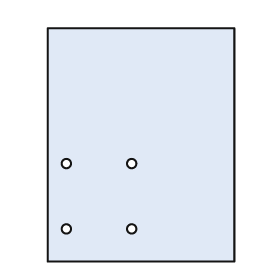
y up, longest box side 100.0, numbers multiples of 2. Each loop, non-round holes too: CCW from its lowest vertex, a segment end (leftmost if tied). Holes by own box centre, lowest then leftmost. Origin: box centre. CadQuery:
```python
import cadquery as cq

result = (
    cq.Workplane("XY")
    .moveTo(-40.0, -50.0)
    .lineTo(40.0, -50.0)
    .lineTo(40.0, 50.0)
    .lineTo(-40.0, 50.0)
    .close()
    .moveTo(-32.0, -36.0)
    .circle(2.0)
    .moveTo(-4.0, -36.0)
    .circle(2.0)
    .moveTo(-32.0, -8.0)
    .circle(2.0)
    .moveTo(-4.0, -8.0)
    .circle(2.0)
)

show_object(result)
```